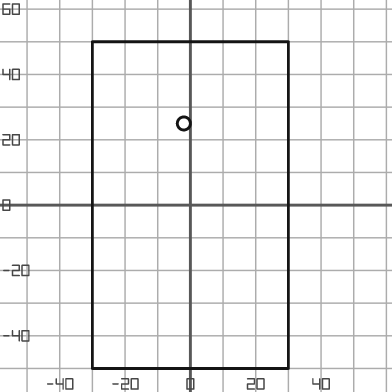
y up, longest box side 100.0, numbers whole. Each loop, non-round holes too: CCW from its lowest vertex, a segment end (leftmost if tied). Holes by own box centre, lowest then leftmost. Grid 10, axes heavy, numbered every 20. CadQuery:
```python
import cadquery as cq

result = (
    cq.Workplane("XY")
    .moveTo(-30.0, -50.0)
    .lineTo(30.0, -50.0)
    .lineTo(30.0, 50.0)
    .lineTo(-30.0, 50.0)
    .close()
    .moveTo(-2.0, 25.0)
    .circle(2.0)
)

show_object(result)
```